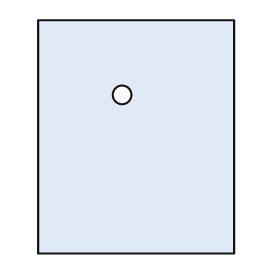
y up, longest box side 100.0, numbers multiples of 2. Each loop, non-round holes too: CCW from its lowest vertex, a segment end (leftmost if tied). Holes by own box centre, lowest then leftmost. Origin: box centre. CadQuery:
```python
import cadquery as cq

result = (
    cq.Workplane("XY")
    .moveTo(-42.0, -50.0)
    .lineTo(42.0, -50.0)
    .lineTo(42.0, 50.0)
    .lineTo(-42.0, 50.0)
    .close()
    .moveTo(-6.0, 18.0)
    .circle(4.0)
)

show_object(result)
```